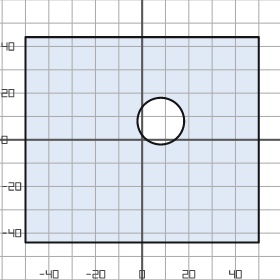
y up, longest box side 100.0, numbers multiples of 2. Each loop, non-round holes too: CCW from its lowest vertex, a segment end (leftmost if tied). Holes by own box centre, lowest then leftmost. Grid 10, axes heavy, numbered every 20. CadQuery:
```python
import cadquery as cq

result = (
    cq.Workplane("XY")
    .moveTo(-50.0, -44.0)
    .lineTo(50.0, -44.0)
    .lineTo(50.0, 44.0)
    .lineTo(-50.0, 44.0)
    .close()
    .moveTo(8.0, 8.0)
    .circle(10.0)
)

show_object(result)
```